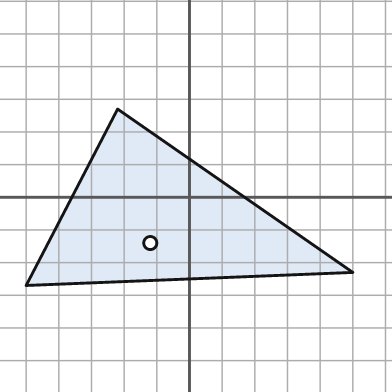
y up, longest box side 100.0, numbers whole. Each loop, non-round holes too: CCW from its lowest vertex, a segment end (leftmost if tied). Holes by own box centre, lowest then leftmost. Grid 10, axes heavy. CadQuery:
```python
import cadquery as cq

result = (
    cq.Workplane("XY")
    .moveTo(-50.0, -27.0)
    .lineTo(50.0, -23.0)
    .lineTo(-22.0, 27.0)
    .close()
    .moveTo(-12.0, -14.0)
    .circle(2.0)
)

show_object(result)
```